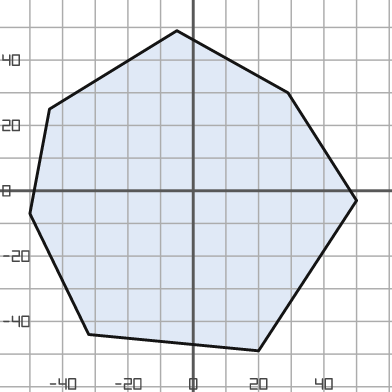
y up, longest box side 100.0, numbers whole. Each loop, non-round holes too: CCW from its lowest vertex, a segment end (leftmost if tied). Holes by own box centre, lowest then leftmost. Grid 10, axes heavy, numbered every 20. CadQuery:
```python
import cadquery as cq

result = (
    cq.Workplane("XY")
    .moveTo(20.0, -49.0)
    .lineTo(50.0, -3.0)
    .lineTo(29.0, 30.0)
    .lineTo(-5.0, 49.0)
    .lineTo(-44.0, 25.0)
    .lineTo(-50.0, -7.0)
    .lineTo(-32.0, -44.0)
    .close()
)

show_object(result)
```